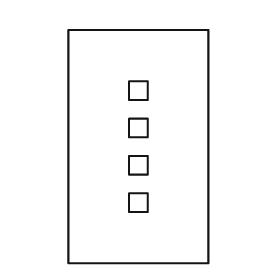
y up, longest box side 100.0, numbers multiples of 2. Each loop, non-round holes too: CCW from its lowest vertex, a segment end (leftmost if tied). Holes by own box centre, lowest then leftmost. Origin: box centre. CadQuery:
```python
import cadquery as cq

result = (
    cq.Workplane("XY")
    .moveTo(-30.0, -50.0)
    .lineTo(30.0, -50.0)
    .lineTo(30.0, 50.0)
    .lineTo(-30.0, 50.0)
    .close()
    .moveTo(-4.0, -28.0)
    .lineTo(4.0, -28.0)
    .lineTo(4.0, -20.0)
    .lineTo(-4.0, -20.0)
    .close()
    .moveTo(-4.0, -12.0)
    .lineTo(4.0, -12.0)
    .lineTo(4.0, -4.0)
    .lineTo(-4.0, -4.0)
    .close()
    .moveTo(-4.0, 4.0)
    .lineTo(4.0, 4.0)
    .lineTo(4.0, 12.0)
    .lineTo(-4.0, 12.0)
    .close()
    .moveTo(-4.0, 20.0)
    .lineTo(4.0, 20.0)
    .lineTo(4.0, 28.0)
    .lineTo(-4.0, 28.0)
    .close()
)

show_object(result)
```